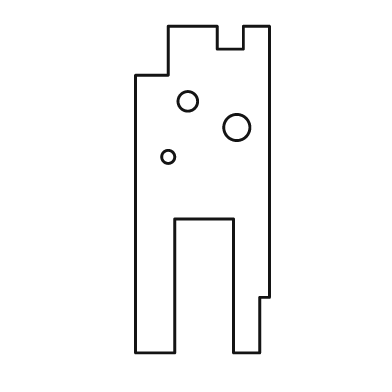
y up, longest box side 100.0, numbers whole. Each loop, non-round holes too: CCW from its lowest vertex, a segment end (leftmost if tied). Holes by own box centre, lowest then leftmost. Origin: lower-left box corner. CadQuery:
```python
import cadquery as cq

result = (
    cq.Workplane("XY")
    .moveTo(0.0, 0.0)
    .lineTo(12.0, 0.0)
    .lineTo(12.0, 41.0)
    .lineTo(30.0, 41.0)
    .lineTo(30.0, 0.0)
    .lineTo(38.0, 0.0)
    .lineTo(38.0, 17.0)
    .lineTo(41.0, 17.0)
    .lineTo(41.0, 100.0)
    .lineTo(33.0, 100.0)
    .lineTo(33.0, 93.0)
    .lineTo(25.0, 93.0)
    .lineTo(25.0, 100.0)
    .lineTo(10.0, 100.0)
    .lineTo(10.0, 85.0)
    .lineTo(0.0, 85.0)
    .close()
    .moveTo(10.0, 60.0)
    .circle(2.0)
    .moveTo(31.0, 69.0)
    .circle(4.0)
    .moveTo(16.0, 77.0)
    .circle(3.0)
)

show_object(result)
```